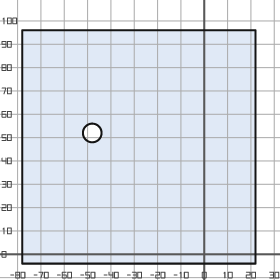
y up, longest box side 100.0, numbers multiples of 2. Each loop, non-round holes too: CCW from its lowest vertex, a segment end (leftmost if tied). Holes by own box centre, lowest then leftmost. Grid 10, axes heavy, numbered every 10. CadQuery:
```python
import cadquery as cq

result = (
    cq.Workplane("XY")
    .moveTo(-78.0, -4.0)
    .lineTo(22.0, -4.0)
    .lineTo(22.0, 96.0)
    .lineTo(-78.0, 96.0)
    .close()
    .moveTo(-48.0, 52.0)
    .circle(4.0)
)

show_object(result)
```